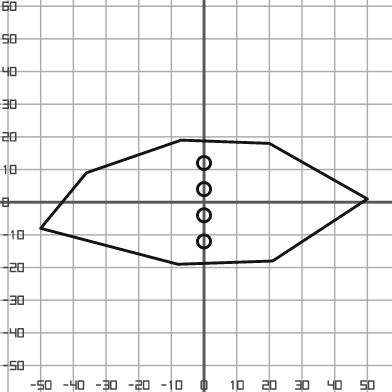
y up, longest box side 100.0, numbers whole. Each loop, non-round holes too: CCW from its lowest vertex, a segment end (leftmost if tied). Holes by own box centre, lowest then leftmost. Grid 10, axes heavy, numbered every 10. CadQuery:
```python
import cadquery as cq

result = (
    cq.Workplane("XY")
    .moveTo(-8.0, -19.0)
    .lineTo(21.0, -18.0)
    .lineTo(50.0, 1.0)
    .lineTo(20.0, 18.0)
    .lineTo(-7.0, 19.0)
    .lineTo(-36.0, 9.0)
    .lineTo(-50.0, -8.0)
    .close()
    .moveTo(0.0, -12.0)
    .circle(2.0)
    .moveTo(0.0, -4.0)
    .circle(2.0)
    .moveTo(0.0, 4.0)
    .circle(2.0)
    .moveTo(0.0, 12.0)
    .circle(2.0)
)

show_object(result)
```